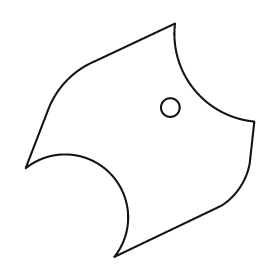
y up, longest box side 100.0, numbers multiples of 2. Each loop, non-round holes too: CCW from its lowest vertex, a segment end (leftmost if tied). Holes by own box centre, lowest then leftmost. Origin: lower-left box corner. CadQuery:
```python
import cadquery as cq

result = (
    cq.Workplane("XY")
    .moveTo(38.0, 0.0)
    .lineTo(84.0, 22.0)
    .threePointArc((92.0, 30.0), (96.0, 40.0))
    .lineTo(98.0, 58.0)
    .threePointArc((72.0, 72.0), (64.0, 100.0))
    .lineTo(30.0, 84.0)
    .threePointArc((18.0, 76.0), (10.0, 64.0))
    .lineTo(0.0, 38.0)
    .threePointArc((36.0, 36.0), (38.0, 0.0))
    .close()
    .moveTo(62.0, 64.0)
    .circle(4.0)
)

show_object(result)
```